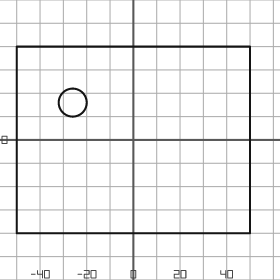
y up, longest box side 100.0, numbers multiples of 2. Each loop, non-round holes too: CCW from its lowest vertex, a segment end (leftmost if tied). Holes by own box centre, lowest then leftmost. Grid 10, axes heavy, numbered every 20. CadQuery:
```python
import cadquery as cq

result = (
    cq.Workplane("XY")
    .moveTo(-50.0, -40.0)
    .lineTo(50.0, -40.0)
    .lineTo(50.0, 40.0)
    .lineTo(-50.0, 40.0)
    .close()
    .moveTo(-26.0, 16.0)
    .circle(6.0)
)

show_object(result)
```